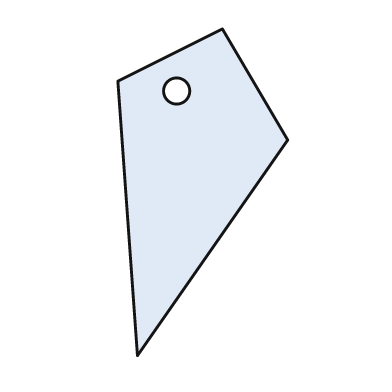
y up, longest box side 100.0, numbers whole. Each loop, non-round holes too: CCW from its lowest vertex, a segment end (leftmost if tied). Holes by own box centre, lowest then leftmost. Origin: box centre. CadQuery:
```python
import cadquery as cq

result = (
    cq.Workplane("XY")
    .moveTo(-20.0, -50.0)
    .lineTo(26.0, 16.0)
    .lineTo(6.0, 50.0)
    .lineTo(-26.0, 34.0)
    .close()
    .moveTo(-8.0, 31.0)
    .circle(4.0)
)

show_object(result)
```